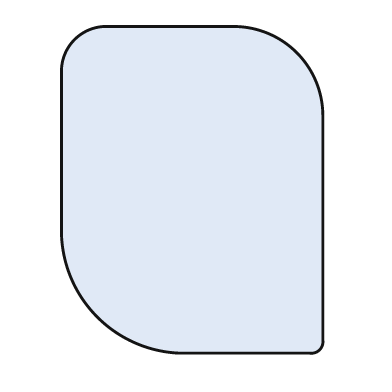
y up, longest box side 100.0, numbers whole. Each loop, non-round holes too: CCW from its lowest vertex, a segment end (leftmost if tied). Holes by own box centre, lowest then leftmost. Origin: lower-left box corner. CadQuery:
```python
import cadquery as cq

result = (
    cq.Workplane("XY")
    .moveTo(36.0, 0.0)
    .lineTo(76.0, 0.0)
    .threePointArc((79.0, 1.0), (80.0, 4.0))
    .lineTo(80.0, 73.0)
    .threePointArc((72.0, 92.0), (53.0, 100.0))
    .lineTo(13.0, 100.0)
    .threePointArc((4.0, 96.0), (0.0, 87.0))
    .lineTo(0.0, 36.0)
    .threePointArc((11.0, 11.0), (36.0, 0.0))
    .close()
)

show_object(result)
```